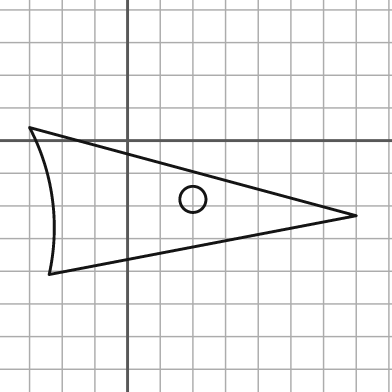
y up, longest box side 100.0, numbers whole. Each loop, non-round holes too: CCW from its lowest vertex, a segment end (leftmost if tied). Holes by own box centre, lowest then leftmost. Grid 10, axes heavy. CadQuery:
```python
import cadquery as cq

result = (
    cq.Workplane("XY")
    .moveTo(-24.0, -41.0)
    .lineTo(70.0, -23.0)
    .lineTo(-30.0, 4.0)
    .threePointArc((-23.0, -18.0), (-24.0, -41.0))
    .close()
    .moveTo(20.0, -18.0)
    .circle(4.0)
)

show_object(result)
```